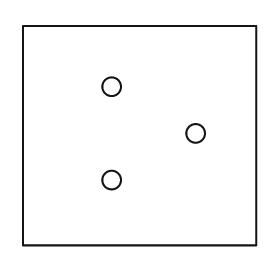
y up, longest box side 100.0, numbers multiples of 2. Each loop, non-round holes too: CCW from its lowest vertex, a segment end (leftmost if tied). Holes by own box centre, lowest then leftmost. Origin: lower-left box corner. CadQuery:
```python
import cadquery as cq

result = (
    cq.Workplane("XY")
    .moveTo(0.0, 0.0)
    .lineTo(100.0, 0.0)
    .lineTo(100.0, 94.0)
    .lineTo(0.0, 94.0)
    .close()
    .moveTo(38.0, 28.0)
    .circle(4.0)
    .moveTo(74.0, 48.0)
    .circle(4.0)
    .moveTo(38.0, 68.0)
    .circle(4.0)
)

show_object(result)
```